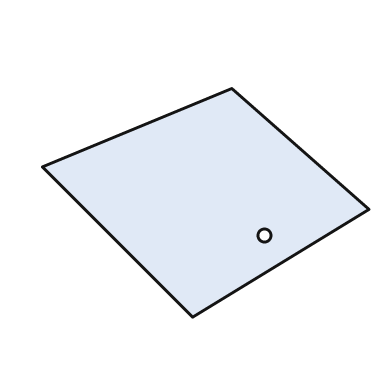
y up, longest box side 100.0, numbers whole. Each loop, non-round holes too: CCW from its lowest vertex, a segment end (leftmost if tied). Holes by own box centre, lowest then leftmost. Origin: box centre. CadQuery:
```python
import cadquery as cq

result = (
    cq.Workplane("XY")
    .moveTo(-4.0, -35.0)
    .lineTo(50.0, -2.0)
    .lineTo(8.0, 35.0)
    .lineTo(-50.0, 11.0)
    .close()
    .moveTo(18.0, -10.0)
    .circle(2.0)
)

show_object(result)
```